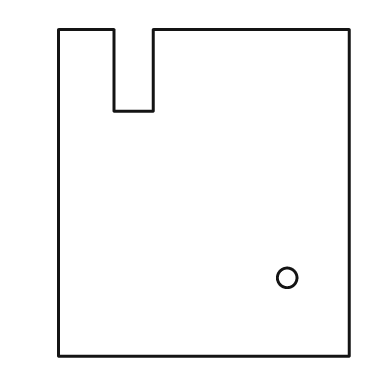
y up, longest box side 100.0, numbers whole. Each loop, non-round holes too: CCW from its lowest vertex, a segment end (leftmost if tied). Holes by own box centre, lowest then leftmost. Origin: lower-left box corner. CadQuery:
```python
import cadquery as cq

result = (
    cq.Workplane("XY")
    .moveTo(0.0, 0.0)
    .lineTo(89.0, 0.0)
    .lineTo(89.0, 100.0)
    .lineTo(29.0, 100.0)
    .lineTo(29.0, 75.0)
    .lineTo(17.0, 75.0)
    .lineTo(17.0, 100.0)
    .lineTo(0.0, 100.0)
    .close()
    .moveTo(70.0, 24.0)
    .circle(3.0)
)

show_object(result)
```